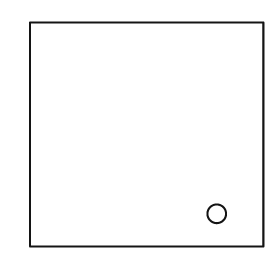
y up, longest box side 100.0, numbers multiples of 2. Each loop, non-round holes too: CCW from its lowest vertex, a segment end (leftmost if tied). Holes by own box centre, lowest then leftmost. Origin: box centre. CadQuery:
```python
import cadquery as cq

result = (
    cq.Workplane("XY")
    .moveTo(-50.0, -48.0)
    .lineTo(50.0, -48.0)
    .lineTo(50.0, 48.0)
    .lineTo(-50.0, 48.0)
    .close()
    .moveTo(30.0, -34.0)
    .circle(4.0)
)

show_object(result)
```